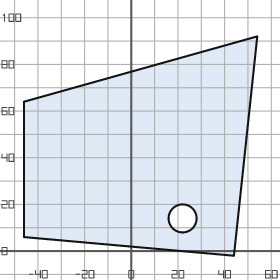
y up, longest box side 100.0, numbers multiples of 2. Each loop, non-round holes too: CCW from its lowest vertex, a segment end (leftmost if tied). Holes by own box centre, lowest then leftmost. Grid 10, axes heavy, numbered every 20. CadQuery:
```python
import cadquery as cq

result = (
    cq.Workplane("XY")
    .moveTo(44.0, -2.0)
    .lineTo(54.0, 92.0)
    .lineTo(-46.0, 64.0)
    .lineTo(-46.0, 6.0)
    .close()
    .moveTo(22.0, 14.0)
    .circle(6.0)
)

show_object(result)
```